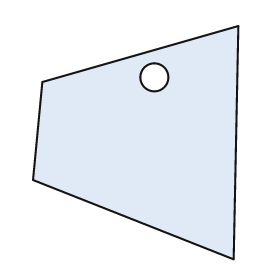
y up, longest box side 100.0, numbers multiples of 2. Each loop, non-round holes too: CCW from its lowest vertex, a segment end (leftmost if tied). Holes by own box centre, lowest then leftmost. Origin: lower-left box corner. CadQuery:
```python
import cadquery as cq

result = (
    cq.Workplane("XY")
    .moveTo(86.0, 0.0)
    .lineTo(88.0, 100.0)
    .lineTo(4.0, 76.0)
    .lineTo(0.0, 34.0)
    .close()
    .moveTo(52.0, 78.0)
    .circle(6.0)
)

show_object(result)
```